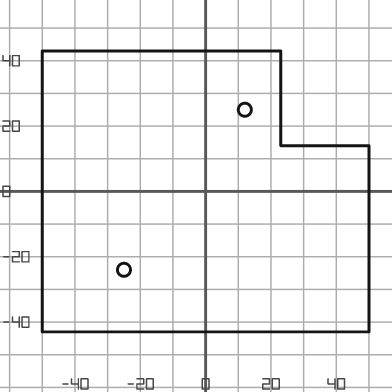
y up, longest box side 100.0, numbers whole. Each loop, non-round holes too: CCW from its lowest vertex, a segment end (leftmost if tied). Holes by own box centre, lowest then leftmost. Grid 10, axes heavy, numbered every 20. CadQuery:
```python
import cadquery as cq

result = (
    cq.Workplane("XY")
    .moveTo(-50.0, -43.0)
    .lineTo(50.0, -43.0)
    .lineTo(50.0, 14.0)
    .lineTo(23.0, 14.0)
    .lineTo(23.0, 43.0)
    .lineTo(-50.0, 43.0)
    .close()
    .moveTo(-25.0, -24.0)
    .circle(2.0)
    .moveTo(12.0, 25.0)
    .circle(2.0)
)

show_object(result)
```